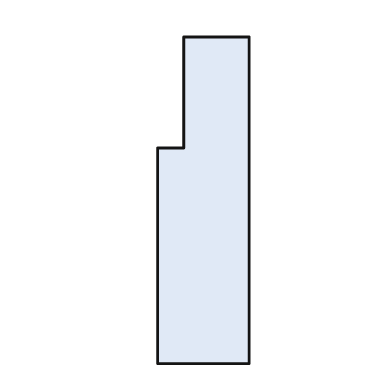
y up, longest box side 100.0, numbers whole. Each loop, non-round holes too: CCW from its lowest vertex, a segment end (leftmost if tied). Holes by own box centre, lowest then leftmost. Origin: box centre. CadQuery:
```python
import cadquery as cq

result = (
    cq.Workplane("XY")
    .moveTo(-14.0, -50.0)
    .lineTo(14.0, -50.0)
    .lineTo(14.0, 50.0)
    .lineTo(-6.0, 50.0)
    .lineTo(-6.0, 16.0)
    .lineTo(-14.0, 16.0)
    .close()
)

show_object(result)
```